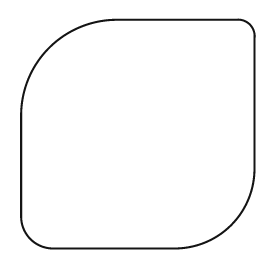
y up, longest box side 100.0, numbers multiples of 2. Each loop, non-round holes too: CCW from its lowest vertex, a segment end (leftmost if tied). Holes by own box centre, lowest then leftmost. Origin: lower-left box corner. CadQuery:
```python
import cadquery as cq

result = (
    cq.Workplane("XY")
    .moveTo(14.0, 0.0)
    .lineTo(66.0, 0.0)
    .threePointArc((90.0, 10.0), (100.0, 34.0))
    .lineTo(100.0, 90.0)
    .threePointArc((98.0, 96.0), (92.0, 98.0))
    .lineTo(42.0, 98.0)
    .threePointArc((12.0, 86.0), (0.0, 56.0))
    .lineTo(0.0, 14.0)
    .threePointArc((4.0, 4.0), (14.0, 0.0))
    .close()
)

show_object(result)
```